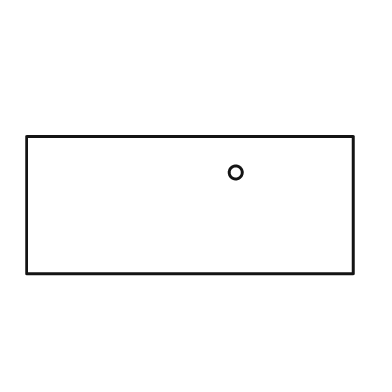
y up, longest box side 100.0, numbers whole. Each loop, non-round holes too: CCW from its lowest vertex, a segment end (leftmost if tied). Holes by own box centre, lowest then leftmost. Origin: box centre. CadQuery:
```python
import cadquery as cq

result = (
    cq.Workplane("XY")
    .moveTo(-50.0, -21.0)
    .lineTo(50.0, -21.0)
    .lineTo(50.0, 21.0)
    .lineTo(-50.0, 21.0)
    .close()
    .moveTo(14.0, 10.0)
    .circle(2.0)
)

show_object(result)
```